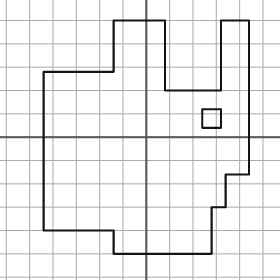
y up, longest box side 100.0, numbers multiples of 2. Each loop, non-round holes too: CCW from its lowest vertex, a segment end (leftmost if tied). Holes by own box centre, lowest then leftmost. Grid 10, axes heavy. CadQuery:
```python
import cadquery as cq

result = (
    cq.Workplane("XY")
    .moveTo(-14.0, -50.0)
    .lineTo(28.0, -50.0)
    .lineTo(28.0, -30.0)
    .lineTo(34.0, -30.0)
    .lineTo(34.0, -16.0)
    .lineTo(44.0, -16.0)
    .lineTo(44.0, 50.0)
    .lineTo(32.0, 50.0)
    .lineTo(32.0, 20.0)
    .lineTo(8.0, 20.0)
    .lineTo(8.0, 50.0)
    .lineTo(-14.0, 50.0)
    .lineTo(-14.0, 28.0)
    .lineTo(-44.0, 28.0)
    .lineTo(-44.0, -40.0)
    .lineTo(-14.0, -40.0)
    .close()
    .moveTo(24.0, 4.0)
    .lineTo(32.0, 4.0)
    .lineTo(32.0, 12.0)
    .lineTo(24.0, 12.0)
    .close()
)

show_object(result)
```